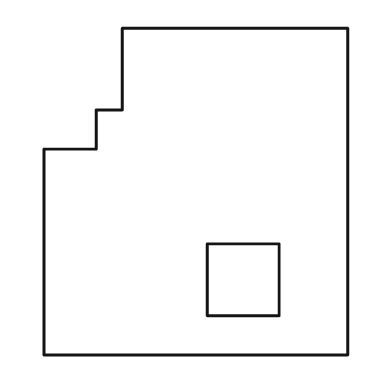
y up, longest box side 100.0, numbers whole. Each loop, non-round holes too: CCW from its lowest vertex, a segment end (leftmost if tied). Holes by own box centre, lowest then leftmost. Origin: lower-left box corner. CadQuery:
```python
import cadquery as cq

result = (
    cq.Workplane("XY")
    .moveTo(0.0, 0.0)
    .lineTo(93.0, 0.0)
    .lineTo(93.0, 100.0)
    .lineTo(24.0, 100.0)
    .lineTo(24.0, 75.0)
    .lineTo(16.0, 75.0)
    .lineTo(16.0, 63.0)
    .lineTo(0.0, 63.0)
    .close()
    .moveTo(50.0, 12.0)
    .lineTo(72.0, 12.0)
    .lineTo(72.0, 34.0)
    .lineTo(50.0, 34.0)
    .close()
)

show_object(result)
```